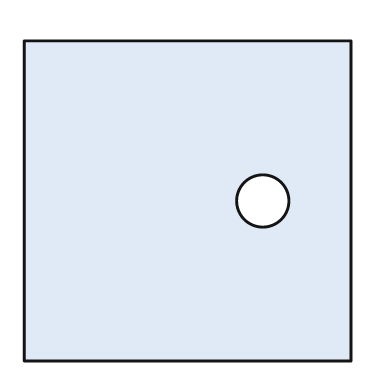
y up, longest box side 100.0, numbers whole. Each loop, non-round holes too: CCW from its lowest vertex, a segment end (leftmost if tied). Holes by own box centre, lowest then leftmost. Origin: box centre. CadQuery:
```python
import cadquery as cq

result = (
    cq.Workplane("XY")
    .moveTo(-50.0, -49.0)
    .lineTo(50.0, -49.0)
    .lineTo(50.0, 49.0)
    .lineTo(-50.0, 49.0)
    .close()
    .moveTo(23.0, 0.0)
    .circle(8.0)
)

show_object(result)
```